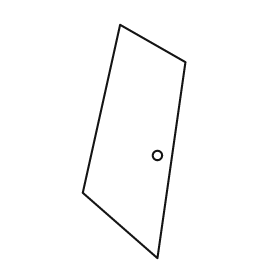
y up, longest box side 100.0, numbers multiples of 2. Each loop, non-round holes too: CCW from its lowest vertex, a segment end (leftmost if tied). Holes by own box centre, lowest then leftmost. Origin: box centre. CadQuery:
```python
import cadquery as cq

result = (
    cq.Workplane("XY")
    .moveTo(10.0, -50.0)
    .lineTo(22.0, 34.0)
    .lineTo(-6.0, 50.0)
    .lineTo(-22.0, -22.0)
    .close()
    .moveTo(10.0, -6.0)
    .circle(2.0)
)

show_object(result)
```